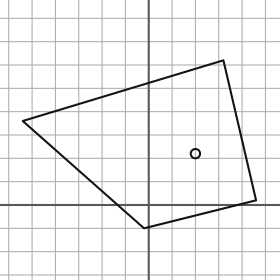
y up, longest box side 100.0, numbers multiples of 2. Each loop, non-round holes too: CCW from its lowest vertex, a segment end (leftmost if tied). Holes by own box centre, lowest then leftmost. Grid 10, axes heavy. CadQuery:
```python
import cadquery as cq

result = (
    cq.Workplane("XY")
    .moveTo(-2.0, -10.0)
    .lineTo(46.0, 2.0)
    .lineTo(32.0, 62.0)
    .lineTo(-54.0, 36.0)
    .close()
    .moveTo(20.0, 22.0)
    .circle(2.0)
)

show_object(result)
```